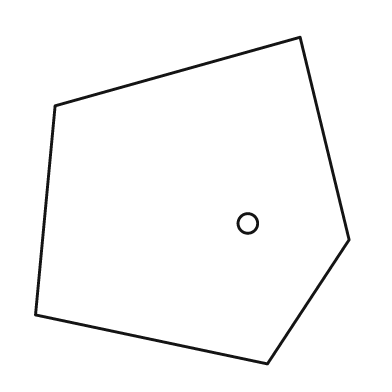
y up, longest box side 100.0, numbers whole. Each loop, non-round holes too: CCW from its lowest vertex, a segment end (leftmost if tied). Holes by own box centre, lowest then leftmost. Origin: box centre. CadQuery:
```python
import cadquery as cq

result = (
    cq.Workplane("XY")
    .moveTo(23.0, -50.0)
    .lineTo(48.0, -12.0)
    .lineTo(33.0, 50.0)
    .lineTo(-42.0, 29.0)
    .lineTo(-48.0, -35.0)
    .close()
    .moveTo(17.0, -7.0)
    .circle(3.0)
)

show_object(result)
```